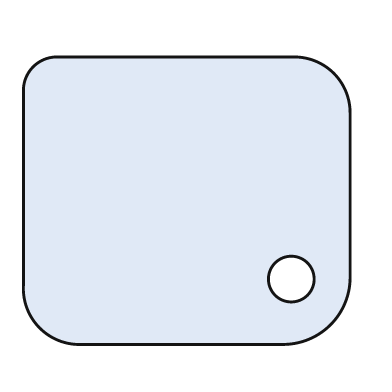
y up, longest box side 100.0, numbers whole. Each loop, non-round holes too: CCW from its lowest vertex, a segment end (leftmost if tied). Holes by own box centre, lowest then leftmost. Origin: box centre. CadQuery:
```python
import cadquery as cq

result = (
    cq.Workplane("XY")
    .moveTo(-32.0, -44.0)
    .lineTo(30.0, -44.0)
    .threePointArc((44.0, -38.0), (50.0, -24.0))
    .lineTo(50.0, 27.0)
    .threePointArc((45.0, 39.0), (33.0, 44.0))
    .lineTo(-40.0, 44.0)
    .threePointArc((-47.0, 41.0), (-50.0, 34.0))
    .lineTo(-50.0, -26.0)
    .threePointArc((-45.0, -39.0), (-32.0, -44.0))
    .close()
    .moveTo(32.0, -24.0)
    .circle(7.0)
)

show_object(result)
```